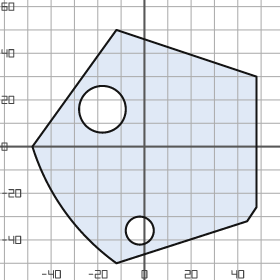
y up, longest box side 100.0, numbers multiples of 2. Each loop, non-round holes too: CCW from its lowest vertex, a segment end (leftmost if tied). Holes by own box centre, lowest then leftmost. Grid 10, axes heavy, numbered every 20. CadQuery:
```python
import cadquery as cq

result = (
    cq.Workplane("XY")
    .moveTo(-12.0, -50.0)
    .lineTo(44.0, -32.0)
    .lineTo(48.0, -26.0)
    .lineTo(48.0, 30.0)
    .lineTo(-12.0, 50.0)
    .lineTo(-48.0, 0.0)
    .threePointArc((-34.0, -28.0), (-12.0, -50.0))
    .close()
    .moveTo(-2.0, -36.0)
    .circle(6.0)
    .moveTo(-18.0, 16.0)
    .circle(10.0)
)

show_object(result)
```